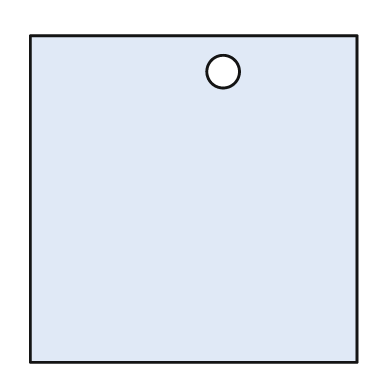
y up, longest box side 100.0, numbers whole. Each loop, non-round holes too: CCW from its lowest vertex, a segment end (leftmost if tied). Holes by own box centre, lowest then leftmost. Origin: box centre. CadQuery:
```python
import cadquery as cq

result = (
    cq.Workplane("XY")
    .moveTo(-50.0, -50.0)
    .lineTo(50.0, -50.0)
    .lineTo(50.0, 50.0)
    .lineTo(-50.0, 50.0)
    .close()
    .moveTo(9.0, 39.0)
    .circle(5.0)
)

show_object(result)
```